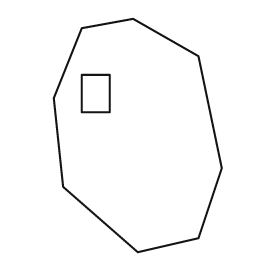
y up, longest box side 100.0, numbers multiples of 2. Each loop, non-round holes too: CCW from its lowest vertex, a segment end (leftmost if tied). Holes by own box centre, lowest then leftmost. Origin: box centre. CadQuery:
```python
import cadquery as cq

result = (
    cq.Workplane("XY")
    .moveTo(0.0, -50.0)
    .lineTo(26.0, -44.0)
    .lineTo(36.0, -14.0)
    .lineTo(26.0, 34.0)
    .lineTo(-2.0, 50.0)
    .lineTo(-24.0, 46.0)
    .lineTo(-36.0, 16.0)
    .lineTo(-32.0, -22.0)
    .close()
    .moveTo(-24.0, 10.0)
    .lineTo(-12.0, 10.0)
    .lineTo(-12.0, 26.0)
    .lineTo(-24.0, 26.0)
    .close()
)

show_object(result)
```